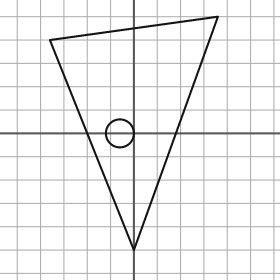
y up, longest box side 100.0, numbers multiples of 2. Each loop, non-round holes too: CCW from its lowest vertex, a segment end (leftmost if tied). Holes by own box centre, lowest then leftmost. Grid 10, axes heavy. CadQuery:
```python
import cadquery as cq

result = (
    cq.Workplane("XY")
    .moveTo(0.0, -50.0)
    .lineTo(36.0, 50.0)
    .lineTo(-36.0, 40.0)
    .close()
    .moveTo(-6.0, 0.0)
    .circle(6.0)
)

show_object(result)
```